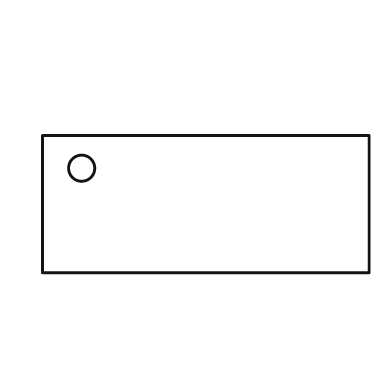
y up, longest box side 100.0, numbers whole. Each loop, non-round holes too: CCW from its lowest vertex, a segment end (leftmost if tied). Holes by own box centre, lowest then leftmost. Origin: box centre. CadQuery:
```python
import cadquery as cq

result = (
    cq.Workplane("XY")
    .moveTo(-50.0, -21.0)
    .lineTo(50.0, -21.0)
    .lineTo(50.0, 21.0)
    .lineTo(-50.0, 21.0)
    .close()
    .moveTo(-38.0, 11.0)
    .circle(4.0)
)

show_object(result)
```